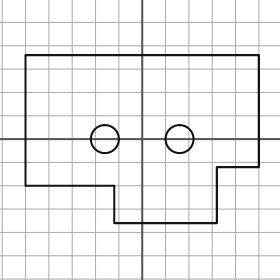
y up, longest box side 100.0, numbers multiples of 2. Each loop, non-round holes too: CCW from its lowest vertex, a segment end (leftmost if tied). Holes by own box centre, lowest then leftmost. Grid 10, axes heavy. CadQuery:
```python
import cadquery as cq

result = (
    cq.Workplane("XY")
    .moveTo(-12.0, -36.0)
    .lineTo(32.0, -36.0)
    .lineTo(32.0, -12.0)
    .lineTo(50.0, -12.0)
    .lineTo(50.0, 36.0)
    .lineTo(-50.0, 36.0)
    .lineTo(-50.0, -20.0)
    .lineTo(-12.0, -20.0)
    .close()
    .moveTo(-16.0, 0.0)
    .circle(6.0)
    .moveTo(16.0, 0.0)
    .circle(6.0)
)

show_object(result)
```